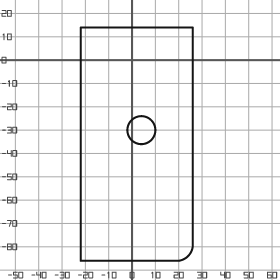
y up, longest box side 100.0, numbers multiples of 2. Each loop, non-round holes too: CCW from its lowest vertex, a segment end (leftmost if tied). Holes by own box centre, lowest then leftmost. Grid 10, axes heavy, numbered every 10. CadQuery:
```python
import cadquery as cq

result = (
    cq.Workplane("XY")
    .moveTo(-22.0, -86.0)
    .lineTo(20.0, -86.0)
    .threePointArc((24.0, -84.0), (26.0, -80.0))
    .lineTo(26.0, 14.0)
    .lineTo(-22.0, 14.0)
    .close()
    .moveTo(4.0, -30.0)
    .circle(6.0)
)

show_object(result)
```